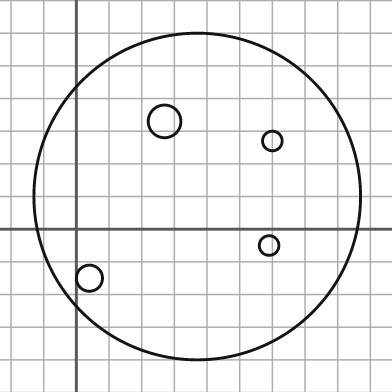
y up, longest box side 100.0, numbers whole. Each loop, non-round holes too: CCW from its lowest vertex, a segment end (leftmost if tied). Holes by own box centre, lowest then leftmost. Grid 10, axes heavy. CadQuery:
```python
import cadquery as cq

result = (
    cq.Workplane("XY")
    .moveTo(37.0, 10.0)
    .circle(50.0)
    .moveTo(4.0, -15.0)
    .circle(4.0)
    .moveTo(59.0, -5.0)
    .circle(3.0)
    .moveTo(60.0, 27.0)
    .circle(3.0)
    .moveTo(27.0, 33.0)
    .circle(5.0)
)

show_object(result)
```